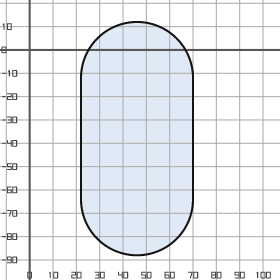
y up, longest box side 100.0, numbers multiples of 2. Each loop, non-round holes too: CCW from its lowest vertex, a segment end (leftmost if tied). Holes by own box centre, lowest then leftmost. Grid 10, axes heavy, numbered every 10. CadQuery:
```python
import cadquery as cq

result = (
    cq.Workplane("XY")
    .moveTo(22.0, -64.0)
    .threePointArc((46.0, -88.0), (70.0, -64.0))
    .lineTo(70.0, -12.0)
    .threePointArc((46.0, 12.0), (22.0, -12.0))
    .close()
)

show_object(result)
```